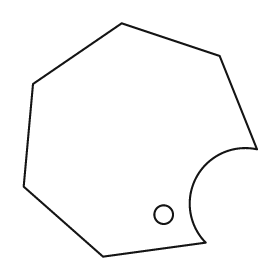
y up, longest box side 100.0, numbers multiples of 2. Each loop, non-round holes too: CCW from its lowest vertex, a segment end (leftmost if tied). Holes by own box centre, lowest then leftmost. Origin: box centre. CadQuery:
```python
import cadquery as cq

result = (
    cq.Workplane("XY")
    .moveTo(-16.0, -50.0)
    .lineTo(28.0, -44.0)
    .threePointArc((24.0, -16.0), (50.0, -4.0))
    .lineTo(34.0, 36.0)
    .lineTo(-8.0, 50.0)
    .lineTo(-46.0, 24.0)
    .lineTo(-50.0, -20.0)
    .close()
    .moveTo(10.0, -32.0)
    .circle(4.0)
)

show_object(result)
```